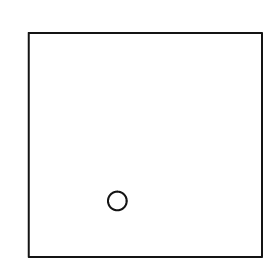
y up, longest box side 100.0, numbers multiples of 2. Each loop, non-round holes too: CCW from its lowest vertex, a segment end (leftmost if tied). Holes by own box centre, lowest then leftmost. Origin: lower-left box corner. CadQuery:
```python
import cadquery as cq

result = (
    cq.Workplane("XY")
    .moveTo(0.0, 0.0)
    .lineTo(100.0, 0.0)
    .lineTo(100.0, 96.0)
    .lineTo(0.0, 96.0)
    .close()
    .moveTo(38.0, 24.0)
    .circle(4.0)
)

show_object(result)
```